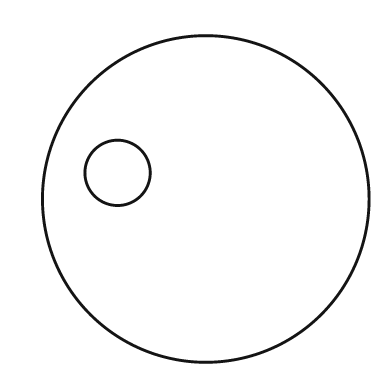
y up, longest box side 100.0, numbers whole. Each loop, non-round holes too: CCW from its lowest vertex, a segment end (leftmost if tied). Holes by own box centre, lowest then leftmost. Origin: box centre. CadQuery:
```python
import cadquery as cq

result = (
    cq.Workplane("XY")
    .moveTo(0.0, 0.0)
    .circle(50.0)
    .moveTo(-27.0, 8.0)
    .circle(10.0)
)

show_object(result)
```